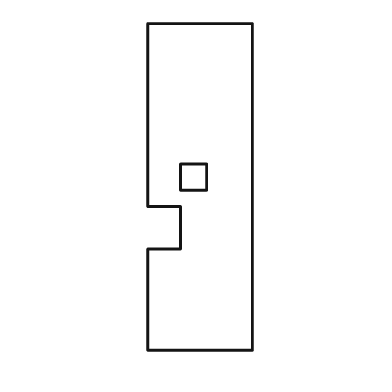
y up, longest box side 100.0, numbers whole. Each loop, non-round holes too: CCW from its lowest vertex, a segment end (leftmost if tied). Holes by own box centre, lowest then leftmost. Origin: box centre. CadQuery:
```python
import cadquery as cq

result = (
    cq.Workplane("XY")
    .moveTo(-16.0, -50.0)
    .lineTo(16.0, -50.0)
    .lineTo(16.0, 50.0)
    .lineTo(-16.0, 50.0)
    .lineTo(-16.0, -6.0)
    .lineTo(-6.0, -6.0)
    .lineTo(-6.0, -19.0)
    .lineTo(-16.0, -19.0)
    .close()
    .moveTo(-6.0, -1.0)
    .lineTo(2.0, -1.0)
    .lineTo(2.0, 7.0)
    .lineTo(-6.0, 7.0)
    .close()
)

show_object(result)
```